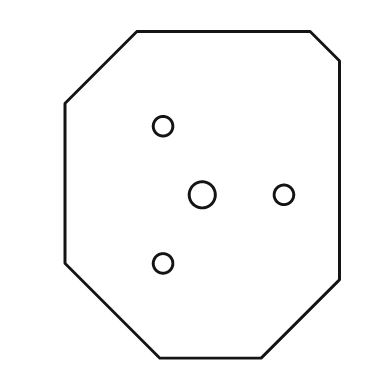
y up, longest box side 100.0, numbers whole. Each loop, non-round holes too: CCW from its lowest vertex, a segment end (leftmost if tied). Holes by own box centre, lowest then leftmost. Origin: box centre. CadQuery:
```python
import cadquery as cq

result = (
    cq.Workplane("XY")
    .moveTo(-13.0, -50.0)
    .lineTo(18.0, -50.0)
    .lineTo(42.0, -26.0)
    .lineTo(42.0, 41.0)
    .lineTo(33.0, 50.0)
    .lineTo(-20.0, 50.0)
    .lineTo(-42.0, 28.0)
    .lineTo(-42.0, -21.0)
    .close()
    .moveTo(-12.0, -21.0)
    .circle(3.0)
    .moveTo(0.0, 0.0)
    .circle(4.0)
    .moveTo(25.0, 0.0)
    .circle(3.0)
    .moveTo(-12.0, 21.0)
    .circle(3.0)
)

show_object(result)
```